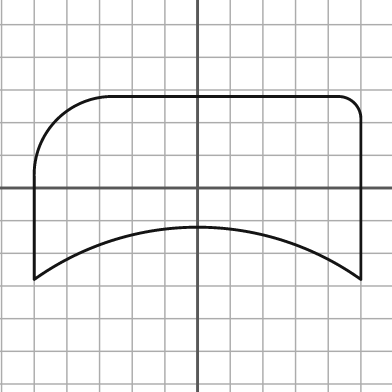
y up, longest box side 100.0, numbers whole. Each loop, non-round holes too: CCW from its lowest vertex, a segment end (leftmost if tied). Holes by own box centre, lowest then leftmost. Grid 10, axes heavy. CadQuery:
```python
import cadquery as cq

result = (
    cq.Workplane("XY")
    .moveTo(-50.0, -28.0)
    .threePointArc((0.0, -12.0), (50.0, -28.0))
    .lineTo(50.0, 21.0)
    .threePointArc((48.0, 26.0), (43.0, 28.0))
    .lineTo(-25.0, 28.0)
    .threePointArc((-43.0, 21.0), (-50.0, 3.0))
    .close()
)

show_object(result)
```